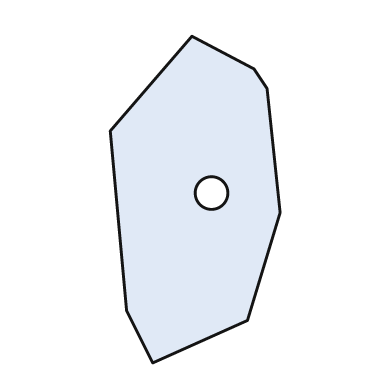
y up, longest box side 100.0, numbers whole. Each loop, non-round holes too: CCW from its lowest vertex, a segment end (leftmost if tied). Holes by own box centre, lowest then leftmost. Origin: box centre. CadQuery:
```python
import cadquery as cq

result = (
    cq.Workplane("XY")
    .moveTo(-13.0, -50.0)
    .lineTo(16.0, -37.0)
    .lineTo(26.0, -4.0)
    .lineTo(22.0, 34.0)
    .lineTo(18.0, 40.0)
    .lineTo(-1.0, 50.0)
    .lineTo(-26.0, 21.0)
    .lineTo(-21.0, -34.0)
    .close()
    .moveTo(5.0, 2.0)
    .circle(5.0)
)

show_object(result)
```